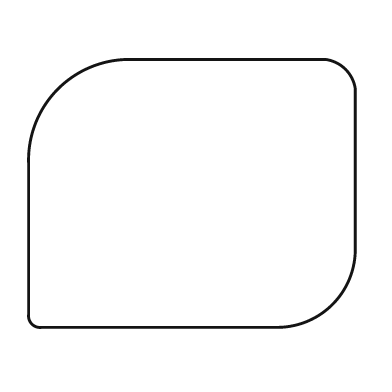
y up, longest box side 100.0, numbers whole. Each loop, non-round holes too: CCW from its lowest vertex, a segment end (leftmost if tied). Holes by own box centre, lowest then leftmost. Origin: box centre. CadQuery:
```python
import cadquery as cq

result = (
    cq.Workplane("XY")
    .moveTo(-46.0, -41.0)
    .lineTo(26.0, -41.0)
    .threePointArc((43.0, -34.0), (50.0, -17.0))
    .lineTo(50.0, 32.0)
    .threePointArc((47.0, 38.0), (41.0, 41.0))
    .lineTo(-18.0, 41.0)
    .threePointArc((-41.0, 32.0), (-50.0, 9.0))
    .lineTo(-50.0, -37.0)
    .threePointArc((-49.0, -40.0), (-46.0, -41.0))
    .close()
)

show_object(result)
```